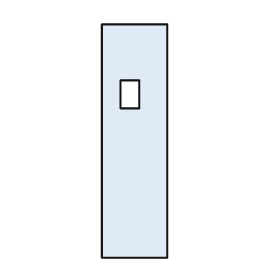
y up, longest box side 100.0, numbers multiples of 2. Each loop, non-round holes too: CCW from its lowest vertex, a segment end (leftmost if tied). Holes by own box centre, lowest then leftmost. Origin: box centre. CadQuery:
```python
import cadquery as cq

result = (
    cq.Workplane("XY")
    .moveTo(-14.0, -50.0)
    .lineTo(14.0, -50.0)
    .lineTo(14.0, 50.0)
    .lineTo(-14.0, 50.0)
    .close()
    .moveTo(-6.0, 14.0)
    .lineTo(2.0, 14.0)
    .lineTo(2.0, 26.0)
    .lineTo(-6.0, 26.0)
    .close()
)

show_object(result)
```